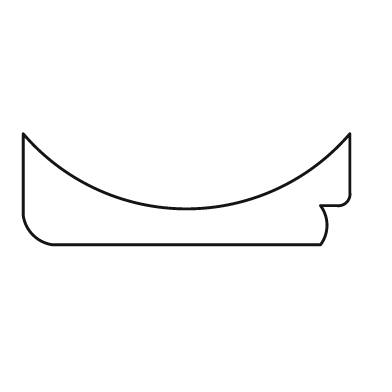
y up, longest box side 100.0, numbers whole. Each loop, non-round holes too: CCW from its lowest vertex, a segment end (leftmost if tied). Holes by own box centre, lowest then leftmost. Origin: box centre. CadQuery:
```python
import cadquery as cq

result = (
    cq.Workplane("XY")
    .moveTo(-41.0, -17.0)
    .lineTo(41.0, -17.0)
    .threePointArc((43.0, -11.0), (41.0, -5.0))
    .lineTo(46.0, -5.0)
    .threePointArc((49.0, -4.0), (50.0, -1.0))
    .lineTo(50.0, 17.0)
    .threePointArc((0.0, -6.0), (-50.0, 17.0))
    .lineTo(-50.0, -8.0)
    .threePointArc((-47.0, -14.0), (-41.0, -17.0))
    .close()
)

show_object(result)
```